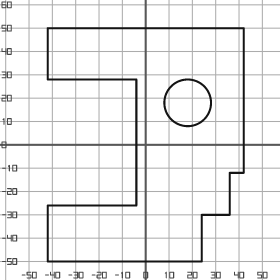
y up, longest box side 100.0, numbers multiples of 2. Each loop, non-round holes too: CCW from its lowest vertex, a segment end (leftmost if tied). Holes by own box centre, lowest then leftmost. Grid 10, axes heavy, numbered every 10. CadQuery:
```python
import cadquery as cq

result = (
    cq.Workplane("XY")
    .moveTo(-42.0, -50.0)
    .lineTo(24.0, -50.0)
    .lineTo(24.0, -30.0)
    .lineTo(36.0, -30.0)
    .lineTo(36.0, -12.0)
    .lineTo(42.0, -12.0)
    .lineTo(42.0, 50.0)
    .lineTo(-42.0, 50.0)
    .lineTo(-42.0, 28.0)
    .lineTo(-4.0, 28.0)
    .lineTo(-4.0, -26.0)
    .lineTo(-42.0, -26.0)
    .close()
    .moveTo(18.0, 18.0)
    .circle(10.0)
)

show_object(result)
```